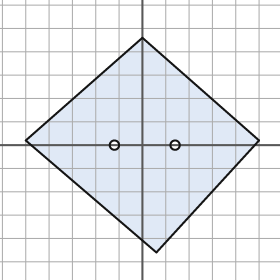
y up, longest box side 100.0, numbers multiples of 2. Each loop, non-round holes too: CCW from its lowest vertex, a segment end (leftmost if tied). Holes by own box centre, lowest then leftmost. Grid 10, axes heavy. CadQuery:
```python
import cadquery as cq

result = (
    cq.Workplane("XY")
    .moveTo(6.0, -46.0)
    .lineTo(50.0, 2.0)
    .lineTo(0.0, 46.0)
    .lineTo(-50.0, 2.0)
    .close()
    .moveTo(-12.0, 0.0)
    .circle(2.0)
    .moveTo(14.0, 0.0)
    .circle(2.0)
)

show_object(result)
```